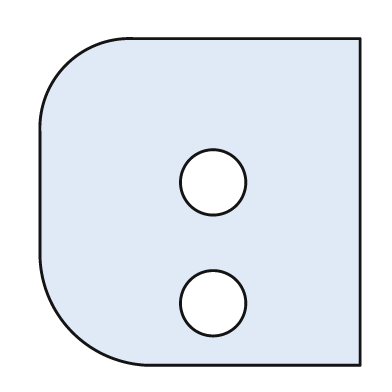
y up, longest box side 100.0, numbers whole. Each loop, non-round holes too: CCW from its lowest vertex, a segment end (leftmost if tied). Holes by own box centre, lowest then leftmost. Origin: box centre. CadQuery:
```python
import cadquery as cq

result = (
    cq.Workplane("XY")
    .moveTo(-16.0, -50.0)
    .lineTo(49.0, -50.0)
    .lineTo(49.0, 50.0)
    .lineTo(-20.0, 50.0)
    .threePointArc((-41.0, 42.0), (-49.0, 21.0))
    .lineTo(-49.0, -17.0)
    .threePointArc((-39.0, -40.0), (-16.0, -50.0))
    .close()
    .moveTo(4.0, -31.0)
    .circle(10.0)
    .moveTo(4.0, 6.0)
    .circle(10.0)
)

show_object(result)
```